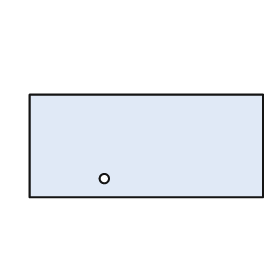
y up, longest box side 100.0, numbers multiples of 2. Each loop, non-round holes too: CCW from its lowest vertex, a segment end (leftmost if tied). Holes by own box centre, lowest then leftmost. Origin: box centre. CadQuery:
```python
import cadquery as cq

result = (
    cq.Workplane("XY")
    .moveTo(-50.0, -22.0)
    .lineTo(50.0, -22.0)
    .lineTo(50.0, 22.0)
    .lineTo(-50.0, 22.0)
    .close()
    .moveTo(-18.0, -14.0)
    .circle(2.0)
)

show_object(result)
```